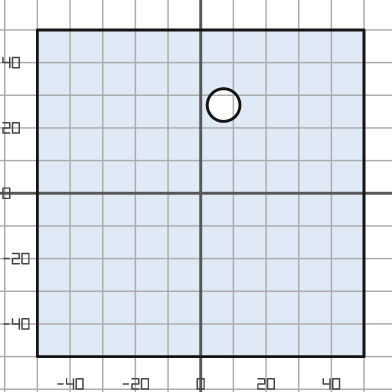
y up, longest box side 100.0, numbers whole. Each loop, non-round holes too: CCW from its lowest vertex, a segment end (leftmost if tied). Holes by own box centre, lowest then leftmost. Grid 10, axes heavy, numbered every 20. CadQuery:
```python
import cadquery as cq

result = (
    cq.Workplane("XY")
    .moveTo(-50.0, -50.0)
    .lineTo(50.0, -50.0)
    .lineTo(50.0, 50.0)
    .lineTo(-50.0, 50.0)
    .close()
    .moveTo(7.0, 27.0)
    .circle(5.0)
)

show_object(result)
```